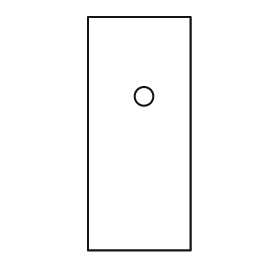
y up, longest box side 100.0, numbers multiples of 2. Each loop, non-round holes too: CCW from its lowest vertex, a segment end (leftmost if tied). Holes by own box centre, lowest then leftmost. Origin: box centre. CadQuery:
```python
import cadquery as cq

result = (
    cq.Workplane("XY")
    .moveTo(-22.0, -50.0)
    .lineTo(22.0, -50.0)
    .lineTo(22.0, 50.0)
    .lineTo(-22.0, 50.0)
    .close()
    .moveTo(2.0, 16.0)
    .circle(4.0)
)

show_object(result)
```